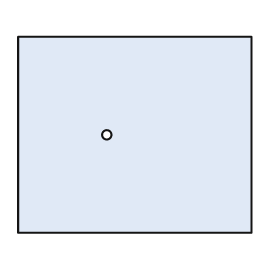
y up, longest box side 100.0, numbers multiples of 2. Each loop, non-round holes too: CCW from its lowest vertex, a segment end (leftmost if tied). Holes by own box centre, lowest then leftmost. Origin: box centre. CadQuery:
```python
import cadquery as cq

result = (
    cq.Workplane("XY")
    .moveTo(-50.0, -42.0)
    .lineTo(50.0, -42.0)
    .lineTo(50.0, 42.0)
    .lineTo(-50.0, 42.0)
    .close()
    .moveTo(-12.0, 0.0)
    .circle(2.0)
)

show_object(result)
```